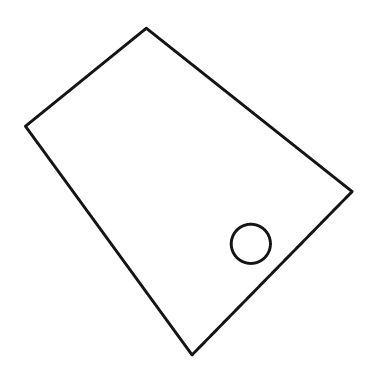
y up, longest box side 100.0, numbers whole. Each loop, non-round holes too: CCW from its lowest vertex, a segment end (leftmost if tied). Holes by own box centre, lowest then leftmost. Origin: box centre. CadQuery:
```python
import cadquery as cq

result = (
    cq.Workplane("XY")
    .moveTo(1.0, -50.0)
    .lineTo(50.0, 0.0)
    .lineTo(-13.0, 50.0)
    .lineTo(-50.0, 20.0)
    .close()
    .moveTo(19.0, -16.0)
    .circle(6.0)
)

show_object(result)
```